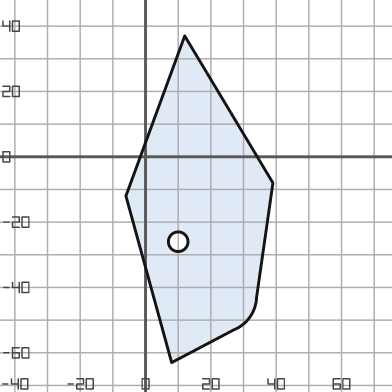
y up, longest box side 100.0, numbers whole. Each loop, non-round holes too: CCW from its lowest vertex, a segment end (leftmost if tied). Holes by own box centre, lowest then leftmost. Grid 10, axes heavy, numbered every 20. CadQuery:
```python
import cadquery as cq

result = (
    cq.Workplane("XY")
    .moveTo(8.0, -63.0)
    .lineTo(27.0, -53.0)
    .threePointArc((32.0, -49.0), (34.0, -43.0))
    .lineTo(39.0, -8.0)
    .lineTo(12.0, 37.0)
    .lineTo(-6.0, -12.0)
    .close()
    .moveTo(10.0, -26.0)
    .circle(3.0)
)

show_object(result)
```